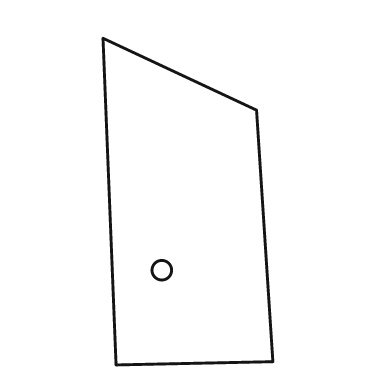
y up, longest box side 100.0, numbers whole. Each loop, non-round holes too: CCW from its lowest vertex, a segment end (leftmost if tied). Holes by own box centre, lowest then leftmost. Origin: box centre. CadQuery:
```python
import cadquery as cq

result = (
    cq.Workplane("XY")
    .moveTo(-22.0, -50.0)
    .lineTo(26.0, -49.0)
    .lineTo(21.0, 28.0)
    .lineTo(-26.0, 50.0)
    .close()
    .moveTo(-8.0, -21.0)
    .circle(3.0)
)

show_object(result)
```